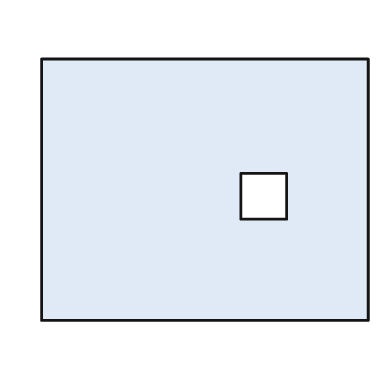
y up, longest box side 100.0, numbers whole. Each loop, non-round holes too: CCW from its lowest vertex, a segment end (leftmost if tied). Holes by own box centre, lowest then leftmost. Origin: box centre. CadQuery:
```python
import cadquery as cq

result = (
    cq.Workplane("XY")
    .moveTo(-50.0, -40.0)
    .lineTo(50.0, -40.0)
    .lineTo(50.0, 40.0)
    .lineTo(-50.0, 40.0)
    .close()
    .moveTo(11.0, -9.0)
    .lineTo(25.0, -9.0)
    .lineTo(25.0, 5.0)
    .lineTo(11.0, 5.0)
    .close()
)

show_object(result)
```